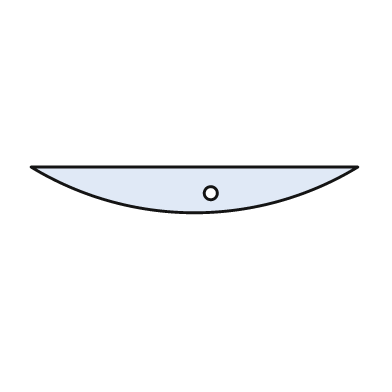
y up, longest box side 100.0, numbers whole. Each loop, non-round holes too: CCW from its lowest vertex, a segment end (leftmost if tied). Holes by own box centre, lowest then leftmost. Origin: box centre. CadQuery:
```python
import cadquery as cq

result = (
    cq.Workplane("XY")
    .moveTo(-50.0, 7.0)
    .threePointArc((0.0, -7.0), (50.0, 7.0))
    .close()
    .moveTo(5.0, -1.0)
    .circle(2.0)
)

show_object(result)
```